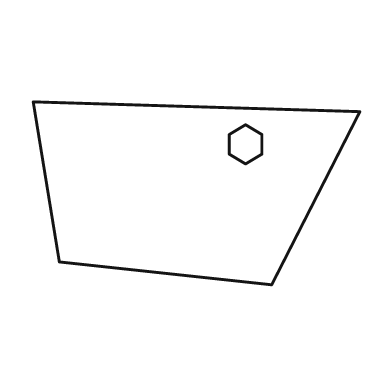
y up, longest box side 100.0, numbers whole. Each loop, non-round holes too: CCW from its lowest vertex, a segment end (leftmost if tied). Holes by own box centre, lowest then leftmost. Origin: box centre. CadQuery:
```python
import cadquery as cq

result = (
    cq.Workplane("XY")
    .moveTo(23.0, -28.0)
    .lineTo(50.0, 25.0)
    .lineTo(-50.0, 28.0)
    .lineTo(-42.0, -21.0)
    .close()
    .moveTo(15.0, 9.0)
    .lineTo(20.0, 12.0)
    .lineTo(20.0, 18.0)
    .lineTo(15.0, 21.0)
    .lineTo(10.0, 18.0)
    .lineTo(10.0, 12.0)
    .close()
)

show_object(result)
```